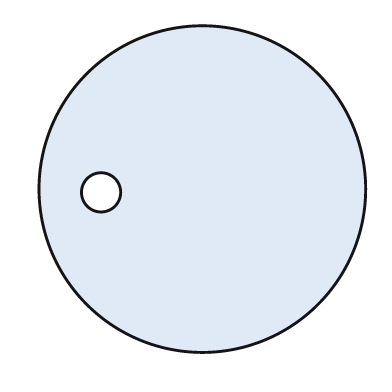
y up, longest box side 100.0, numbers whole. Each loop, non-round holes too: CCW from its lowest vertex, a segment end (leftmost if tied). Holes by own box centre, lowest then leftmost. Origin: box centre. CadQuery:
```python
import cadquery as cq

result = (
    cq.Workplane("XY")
    .moveTo(0.0, 0.0)
    .circle(50.0)
    .moveTo(-31.0, -1.0)
    .circle(6.0)
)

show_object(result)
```